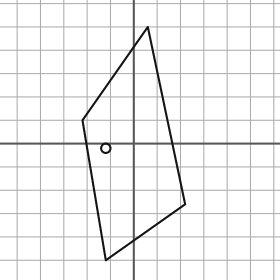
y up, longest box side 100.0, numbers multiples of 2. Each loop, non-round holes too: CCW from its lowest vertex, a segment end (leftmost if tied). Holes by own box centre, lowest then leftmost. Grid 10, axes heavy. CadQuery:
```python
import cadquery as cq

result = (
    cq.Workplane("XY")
    .moveTo(-12.0, -50.0)
    .lineTo(22.0, -26.0)
    .lineTo(6.0, 50.0)
    .lineTo(-22.0, 10.0)
    .close()
    .moveTo(-12.0, -2.0)
    .circle(2.0)
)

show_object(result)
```